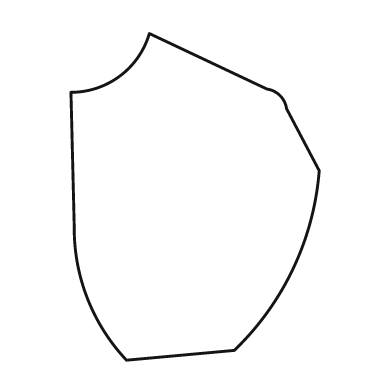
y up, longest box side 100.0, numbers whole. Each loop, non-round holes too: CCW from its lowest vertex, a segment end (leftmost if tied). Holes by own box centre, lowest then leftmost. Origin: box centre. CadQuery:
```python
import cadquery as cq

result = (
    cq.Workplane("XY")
    .moveTo(-21.0, -50.0)
    .lineTo(12.0, -47.0)
    .threePointArc((30.0, -22.0), (38.0, 8.0))
    .lineTo(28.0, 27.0)
    .threePointArc((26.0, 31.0), (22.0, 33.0))
    .lineTo(-14.0, 50.0)
    .threePointArc((-23.0, 37.0), (-38.0, 32.0))
    .lineTo(-37.0, -9.0)
    .threePointArc((-33.0, -31.0), (-21.0, -50.0))
    .close()
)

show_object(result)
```